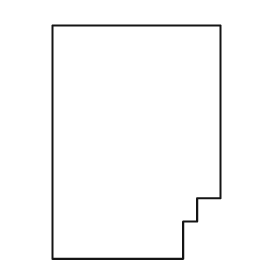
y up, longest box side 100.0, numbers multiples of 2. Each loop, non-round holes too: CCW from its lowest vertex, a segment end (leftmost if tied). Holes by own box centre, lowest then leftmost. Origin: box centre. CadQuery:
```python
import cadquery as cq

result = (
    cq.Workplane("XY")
    .moveTo(-36.0, -50.0)
    .lineTo(20.0, -50.0)
    .lineTo(20.0, -34.0)
    .lineTo(26.0, -34.0)
    .lineTo(26.0, -24.0)
    .lineTo(36.0, -24.0)
    .lineTo(36.0, 50.0)
    .lineTo(-36.0, 50.0)
    .close()
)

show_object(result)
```